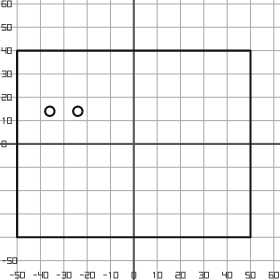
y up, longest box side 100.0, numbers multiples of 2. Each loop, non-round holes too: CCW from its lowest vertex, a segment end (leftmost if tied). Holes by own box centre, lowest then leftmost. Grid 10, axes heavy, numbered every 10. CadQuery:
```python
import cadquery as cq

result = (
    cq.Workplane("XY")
    .moveTo(-50.0, -40.0)
    .lineTo(50.0, -40.0)
    .lineTo(50.0, 40.0)
    .lineTo(-50.0, 40.0)
    .close()
    .moveTo(-36.0, 14.0)
    .circle(2.0)
    .moveTo(-24.0, 14.0)
    .circle(2.0)
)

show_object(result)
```